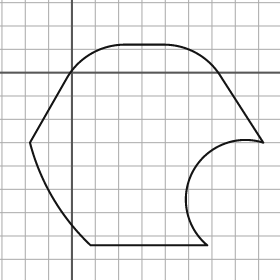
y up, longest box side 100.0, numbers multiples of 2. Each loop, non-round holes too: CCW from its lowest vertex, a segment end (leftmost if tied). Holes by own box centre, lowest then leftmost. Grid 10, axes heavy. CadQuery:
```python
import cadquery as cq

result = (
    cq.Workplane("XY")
    .moveTo(8.0, -74.0)
    .lineTo(58.0, -74.0)
    .threePointArc((52.0, -42.0), (82.0, -30.0))
    .lineTo(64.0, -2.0)
    .threePointArc((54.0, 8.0), (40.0, 12.0))
    .lineTo(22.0, 12.0)
    .threePointArc((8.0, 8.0), (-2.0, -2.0))
    .lineTo(-18.0, -30.0)
    .threePointArc((-8.0, -54.0), (8.0, -74.0))
    .close()
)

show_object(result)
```